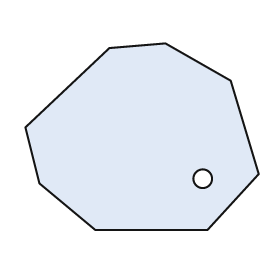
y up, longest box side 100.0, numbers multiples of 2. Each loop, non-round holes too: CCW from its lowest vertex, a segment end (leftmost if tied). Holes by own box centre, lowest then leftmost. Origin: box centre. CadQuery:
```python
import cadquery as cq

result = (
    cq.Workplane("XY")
    .moveTo(-20.0, -40.0)
    .lineTo(28.0, -40.0)
    .lineTo(50.0, -16.0)
    .lineTo(38.0, 24.0)
    .lineTo(10.0, 40.0)
    .lineTo(-14.0, 38.0)
    .lineTo(-50.0, 4.0)
    .lineTo(-44.0, -20.0)
    .close()
    .moveTo(26.0, -18.0)
    .circle(4.0)
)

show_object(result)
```